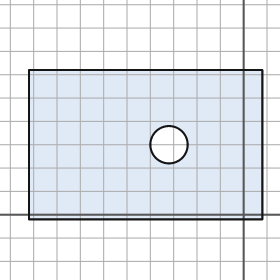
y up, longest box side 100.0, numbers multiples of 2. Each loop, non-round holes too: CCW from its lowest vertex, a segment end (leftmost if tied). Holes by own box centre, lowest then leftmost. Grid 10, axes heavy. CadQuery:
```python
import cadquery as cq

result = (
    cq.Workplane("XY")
    .moveTo(-92.0, -2.0)
    .lineTo(8.0, -2.0)
    .lineTo(8.0, 62.0)
    .lineTo(-92.0, 62.0)
    .close()
    .moveTo(-32.0, 30.0)
    .circle(8.0)
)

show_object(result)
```